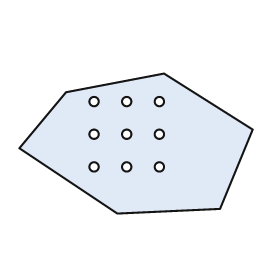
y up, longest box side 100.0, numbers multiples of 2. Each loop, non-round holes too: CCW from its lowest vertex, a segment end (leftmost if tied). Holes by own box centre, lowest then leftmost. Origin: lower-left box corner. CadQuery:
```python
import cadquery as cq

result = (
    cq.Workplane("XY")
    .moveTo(42.0, 0.0)
    .lineTo(86.0, 2.0)
    .lineTo(100.0, 36.0)
    .lineTo(62.0, 60.0)
    .lineTo(20.0, 52.0)
    .lineTo(0.0, 28.0)
    .close()
    .moveTo(32.0, 20.0)
    .circle(2.0)
    .moveTo(46.0, 20.0)
    .circle(2.0)
    .moveTo(60.0, 20.0)
    .circle(2.0)
    .moveTo(32.0, 34.0)
    .circle(2.0)
    .moveTo(46.0, 34.0)
    .circle(2.0)
    .moveTo(60.0, 34.0)
    .circle(2.0)
    .moveTo(32.0, 48.0)
    .circle(2.0)
    .moveTo(46.0, 48.0)
    .circle(2.0)
    .moveTo(60.0, 48.0)
    .circle(2.0)
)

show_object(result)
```